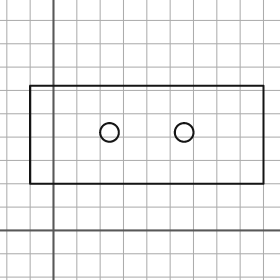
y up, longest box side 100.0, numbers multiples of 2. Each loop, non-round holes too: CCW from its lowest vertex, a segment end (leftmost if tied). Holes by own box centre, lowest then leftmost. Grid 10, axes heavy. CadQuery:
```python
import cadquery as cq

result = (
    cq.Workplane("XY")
    .moveTo(-10.0, 20.0)
    .lineTo(90.0, 20.0)
    .lineTo(90.0, 62.0)
    .lineTo(-10.0, 62.0)
    .close()
    .moveTo(24.0, 42.0)
    .circle(4.0)
    .moveTo(56.0, 42.0)
    .circle(4.0)
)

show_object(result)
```